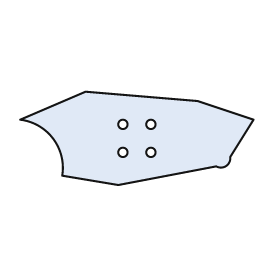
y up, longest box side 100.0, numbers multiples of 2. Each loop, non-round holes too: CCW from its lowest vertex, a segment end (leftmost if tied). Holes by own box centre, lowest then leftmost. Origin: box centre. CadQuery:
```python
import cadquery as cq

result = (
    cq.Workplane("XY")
    .moveTo(-8.0, -20.0)
    .lineTo(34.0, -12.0)
    .threePointArc((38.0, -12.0), (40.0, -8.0))
    .lineTo(50.0, 8.0)
    .lineTo(26.0, 16.0)
    .lineTo(-22.0, 20.0)
    .lineTo(-50.0, 8.0)
    .threePointArc((-36.0, 0.0), (-32.0, -16.0))
    .close()
    .moveTo(-6.0, -6.0)
    .circle(2.0)
    .moveTo(6.0, -6.0)
    .circle(2.0)
    .moveTo(-6.0, 6.0)
    .circle(2.0)
    .moveTo(6.0, 6.0)
    .circle(2.0)
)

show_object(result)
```